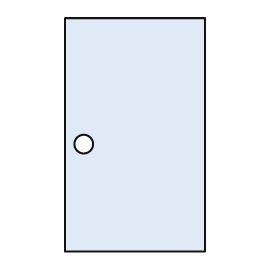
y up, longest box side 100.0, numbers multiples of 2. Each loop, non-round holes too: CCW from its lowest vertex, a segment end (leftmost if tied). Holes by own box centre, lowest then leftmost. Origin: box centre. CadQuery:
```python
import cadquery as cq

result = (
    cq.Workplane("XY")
    .moveTo(-30.0, -50.0)
    .lineTo(30.0, -50.0)
    .lineTo(30.0, 50.0)
    .lineTo(-30.0, 50.0)
    .close()
    .moveTo(-22.0, -4.0)
    .circle(4.0)
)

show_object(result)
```